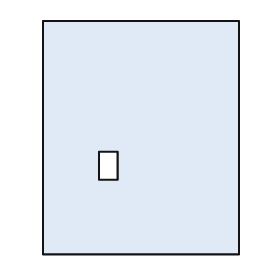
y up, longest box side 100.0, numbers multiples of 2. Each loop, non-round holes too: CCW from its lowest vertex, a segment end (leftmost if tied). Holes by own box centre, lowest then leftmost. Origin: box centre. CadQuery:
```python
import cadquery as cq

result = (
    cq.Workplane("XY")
    .moveTo(-42.0, -50.0)
    .lineTo(42.0, -50.0)
    .lineTo(42.0, 50.0)
    .lineTo(-42.0, 50.0)
    .close()
    .moveTo(-18.0, -18.0)
    .lineTo(-10.0, -18.0)
    .lineTo(-10.0, -6.0)
    .lineTo(-18.0, -6.0)
    .close()
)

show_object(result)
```